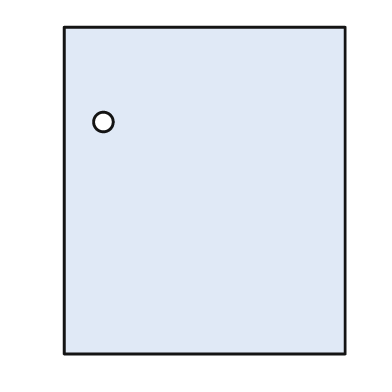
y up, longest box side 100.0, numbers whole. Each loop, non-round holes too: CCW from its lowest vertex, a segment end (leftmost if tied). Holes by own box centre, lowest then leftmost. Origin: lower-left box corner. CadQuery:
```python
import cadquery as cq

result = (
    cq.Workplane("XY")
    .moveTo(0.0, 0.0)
    .lineTo(86.0, 0.0)
    .lineTo(86.0, 100.0)
    .lineTo(0.0, 100.0)
    .close()
    .moveTo(12.0, 71.0)
    .circle(3.0)
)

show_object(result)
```